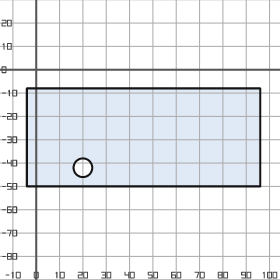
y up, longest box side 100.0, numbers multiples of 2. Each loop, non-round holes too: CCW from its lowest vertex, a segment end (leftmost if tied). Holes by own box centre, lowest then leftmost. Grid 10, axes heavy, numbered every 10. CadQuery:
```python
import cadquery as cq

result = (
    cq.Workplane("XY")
    .moveTo(-4.0, -50.0)
    .lineTo(96.0, -50.0)
    .lineTo(96.0, -8.0)
    .lineTo(-4.0, -8.0)
    .close()
    .moveTo(20.0, -42.0)
    .circle(4.0)
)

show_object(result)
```